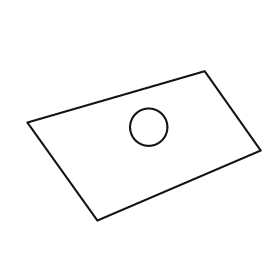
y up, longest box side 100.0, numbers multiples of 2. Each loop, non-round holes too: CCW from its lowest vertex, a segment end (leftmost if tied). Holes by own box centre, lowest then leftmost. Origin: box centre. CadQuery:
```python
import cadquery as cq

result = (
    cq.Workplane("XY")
    .moveTo(-20.0, -32.0)
    .lineTo(50.0, -2.0)
    .lineTo(26.0, 32.0)
    .lineTo(-50.0, 10.0)
    .close()
    .moveTo(2.0, 8.0)
    .circle(8.0)
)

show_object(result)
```